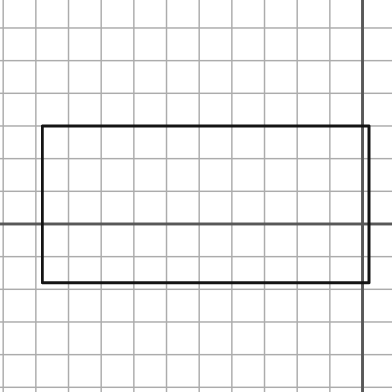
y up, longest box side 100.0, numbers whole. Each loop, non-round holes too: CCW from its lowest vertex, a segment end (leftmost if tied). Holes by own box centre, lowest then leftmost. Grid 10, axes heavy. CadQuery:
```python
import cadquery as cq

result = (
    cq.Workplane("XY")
    .moveTo(-98.0, -18.0)
    .lineTo(2.0, -18.0)
    .lineTo(2.0, 30.0)
    .lineTo(-98.0, 30.0)
    .close()
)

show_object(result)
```